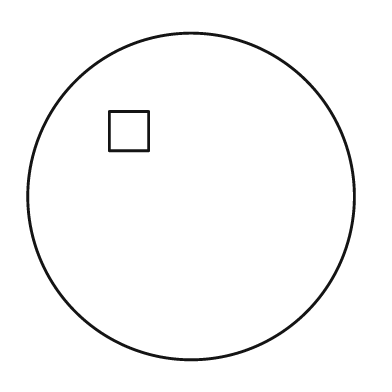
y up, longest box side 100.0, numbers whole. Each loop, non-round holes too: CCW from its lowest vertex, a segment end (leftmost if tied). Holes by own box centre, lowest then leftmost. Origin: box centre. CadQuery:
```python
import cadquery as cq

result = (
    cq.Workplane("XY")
    .moveTo(0.0, 0.0)
    .circle(50.0)
    .moveTo(-25.0, 14.0)
    .lineTo(-13.0, 14.0)
    .lineTo(-13.0, 26.0)
    .lineTo(-25.0, 26.0)
    .close()
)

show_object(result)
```